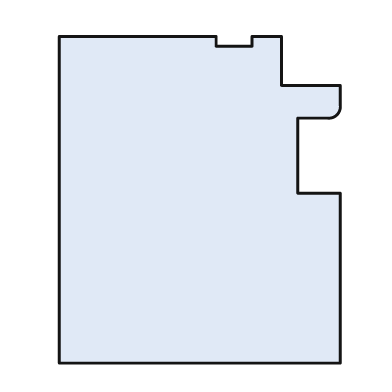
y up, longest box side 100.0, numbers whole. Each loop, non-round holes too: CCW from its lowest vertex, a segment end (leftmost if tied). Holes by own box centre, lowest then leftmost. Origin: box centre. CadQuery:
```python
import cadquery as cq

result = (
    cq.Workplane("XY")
    .moveTo(-43.0, -50.0)
    .lineTo(43.0, -50.0)
    .lineTo(43.0, 2.0)
    .lineTo(30.0, 2.0)
    .lineTo(30.0, 25.0)
    .lineTo(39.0, 25.0)
    .threePointArc((42.0, 26.0), (43.0, 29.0))
    .lineTo(43.0, 35.0)
    .lineTo(25.0, 35.0)
    .lineTo(25.0, 50.0)
    .lineTo(16.0, 50.0)
    .lineTo(16.0, 47.0)
    .lineTo(5.0, 47.0)
    .lineTo(5.0, 50.0)
    .lineTo(-43.0, 50.0)
    .close()
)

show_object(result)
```